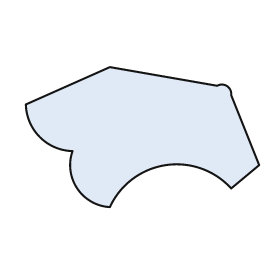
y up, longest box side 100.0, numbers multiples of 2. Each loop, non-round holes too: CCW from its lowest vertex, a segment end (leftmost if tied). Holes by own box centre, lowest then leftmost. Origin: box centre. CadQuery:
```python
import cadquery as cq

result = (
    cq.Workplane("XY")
    .moveTo(-14.0, -30.0)
    .threePointArc((10.0, -12.0), (38.0, -22.0))
    .lineTo(50.0, -12.0)
    .lineTo(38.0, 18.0)
    .threePointArc((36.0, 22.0), (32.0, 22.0))
    .lineTo(-14.0, 30.0)
    .lineTo(-50.0, 14.0)
    .threePointArc((-44.0, 0.0), (-30.0, -6.0))
    .threePointArc((-28.0, -22.0), (-14.0, -30.0))
    .close()
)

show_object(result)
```